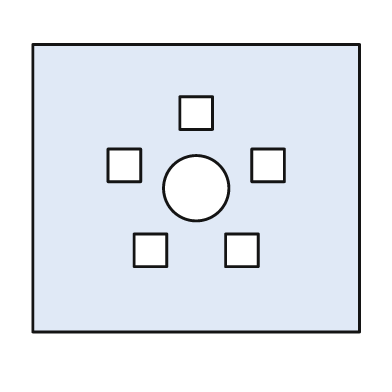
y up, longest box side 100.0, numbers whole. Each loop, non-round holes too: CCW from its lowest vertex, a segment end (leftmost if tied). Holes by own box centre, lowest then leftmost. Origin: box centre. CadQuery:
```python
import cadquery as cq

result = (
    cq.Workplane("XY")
    .moveTo(-50.0, -44.0)
    .lineTo(50.0, -44.0)
    .lineTo(50.0, 44.0)
    .lineTo(-50.0, 44.0)
    .close()
    .moveTo(-19.0, -24.0)
    .lineTo(-9.0, -24.0)
    .lineTo(-9.0, -14.0)
    .lineTo(-19.0, -14.0)
    .close()
    .moveTo(9.0, -24.0)
    .lineTo(19.0, -24.0)
    .lineTo(19.0, -14.0)
    .lineTo(9.0, -14.0)
    .close()
    .moveTo(0.0, 0.0)
    .circle(10.0)
    .moveTo(-27.0, 2.0)
    .lineTo(-17.0, 2.0)
    .lineTo(-17.0, 12.0)
    .lineTo(-27.0, 12.0)
    .close()
    .moveTo(17.0, 2.0)
    .lineTo(27.0, 2.0)
    .lineTo(27.0, 12.0)
    .lineTo(17.0, 12.0)
    .close()
    .moveTo(-5.0, 18.0)
    .lineTo(5.0, 18.0)
    .lineTo(5.0, 28.0)
    .lineTo(-5.0, 28.0)
    .close()
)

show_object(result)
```